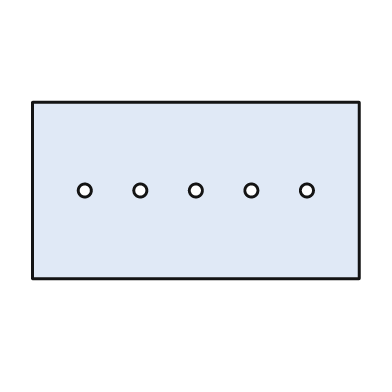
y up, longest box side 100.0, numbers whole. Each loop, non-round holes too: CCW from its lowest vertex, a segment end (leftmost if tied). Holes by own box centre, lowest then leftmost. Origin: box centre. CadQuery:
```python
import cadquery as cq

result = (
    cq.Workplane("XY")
    .moveTo(-50.0, -27.0)
    .lineTo(50.0, -27.0)
    .lineTo(50.0, 27.0)
    .lineTo(-50.0, 27.0)
    .close()
    .moveTo(-34.0, 0.0)
    .circle(2.0)
    .moveTo(-17.0, 0.0)
    .circle(2.0)
    .moveTo(0.0, 0.0)
    .circle(2.0)
    .moveTo(17.0, 0.0)
    .circle(2.0)
    .moveTo(34.0, 0.0)
    .circle(2.0)
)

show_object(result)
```